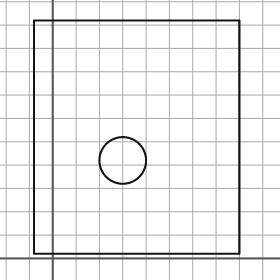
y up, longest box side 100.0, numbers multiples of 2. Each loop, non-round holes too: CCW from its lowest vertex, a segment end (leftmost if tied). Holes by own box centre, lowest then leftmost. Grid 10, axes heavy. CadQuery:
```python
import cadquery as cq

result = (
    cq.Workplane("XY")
    .moveTo(-8.0, 2.0)
    .lineTo(80.0, 2.0)
    .lineTo(80.0, 102.0)
    .lineTo(-8.0, 102.0)
    .close()
    .moveTo(30.0, 42.0)
    .circle(10.0)
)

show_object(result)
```